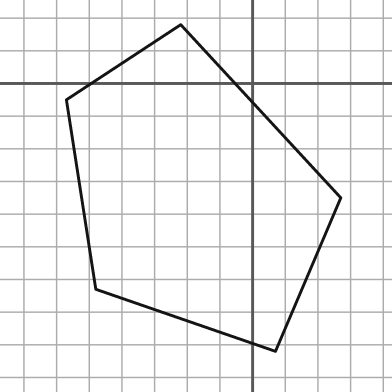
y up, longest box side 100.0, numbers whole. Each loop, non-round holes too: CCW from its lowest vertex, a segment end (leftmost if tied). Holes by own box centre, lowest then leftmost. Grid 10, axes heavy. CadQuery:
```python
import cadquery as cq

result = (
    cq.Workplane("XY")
    .moveTo(7.0, -82.0)
    .lineTo(27.0, -35.0)
    .lineTo(-22.0, 18.0)
    .lineTo(-57.0, -5.0)
    .lineTo(-48.0, -63.0)
    .close()
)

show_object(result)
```